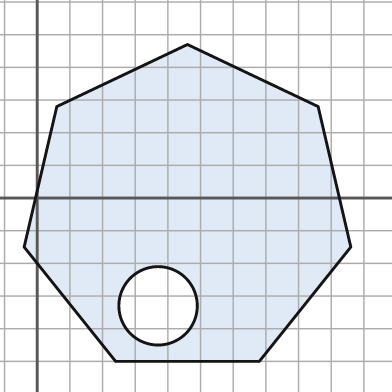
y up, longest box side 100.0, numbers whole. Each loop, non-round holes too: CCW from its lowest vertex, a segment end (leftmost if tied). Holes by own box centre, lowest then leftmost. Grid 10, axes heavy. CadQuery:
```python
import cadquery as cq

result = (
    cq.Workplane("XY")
    .moveTo(24.0, -50.0)
    .lineTo(68.0, -50.0)
    .lineTo(96.0, -15.0)
    .lineTo(86.0, 28.0)
    .lineTo(46.0, 47.0)
    .lineTo(6.0, 28.0)
    .lineTo(-4.0, -15.0)
    .close()
    .moveTo(37.0, -33.0)
    .circle(12.0)
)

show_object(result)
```